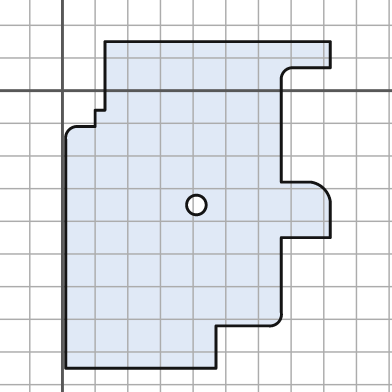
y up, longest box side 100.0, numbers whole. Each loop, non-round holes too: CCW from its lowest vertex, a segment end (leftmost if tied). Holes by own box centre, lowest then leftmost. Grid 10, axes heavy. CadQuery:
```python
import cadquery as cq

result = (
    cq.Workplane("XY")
    .moveTo(1.0, -85.0)
    .lineTo(47.0, -85.0)
    .lineTo(47.0, -72.0)
    .lineTo(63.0, -72.0)
    .threePointArc((66.0, -71.0), (67.0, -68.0))
    .lineTo(67.0, -45.0)
    .lineTo(82.0, -45.0)
    .lineTo(82.0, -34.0)
    .threePointArc((80.0, -30.0), (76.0, -28.0))
    .lineTo(67.0, -28.0)
    .lineTo(67.0, 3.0)
    .threePointArc((68.0, 6.0), (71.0, 7.0))
    .lineTo(82.0, 7.0)
    .lineTo(82.0, 15.0)
    .lineTo(13.0, 15.0)
    .lineTo(13.0, -6.0)
    .lineTo(10.0, -6.0)
    .lineTo(10.0, -11.0)
    .lineTo(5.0, -11.0)
    .threePointArc((2.0, -12.0), (1.0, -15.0))
    .close()
    .moveTo(41.0, -35.0)
    .circle(3.0)
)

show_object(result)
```